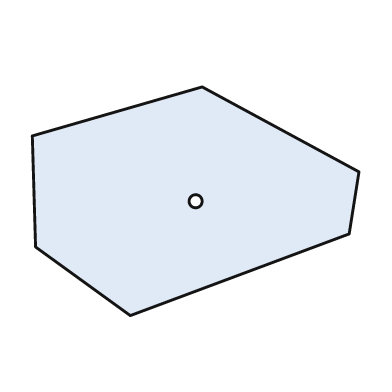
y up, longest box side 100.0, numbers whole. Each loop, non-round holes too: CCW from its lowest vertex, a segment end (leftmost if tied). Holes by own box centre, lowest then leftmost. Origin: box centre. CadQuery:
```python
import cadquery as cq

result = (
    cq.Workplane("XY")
    .moveTo(-20.0, -35.0)
    .lineTo(47.0, -10.0)
    .lineTo(50.0, 9.0)
    .lineTo(2.0, 35.0)
    .lineTo(-50.0, 20.0)
    .lineTo(-49.0, -14.0)
    .close()
    .moveTo(0.0, 0.0)
    .circle(2.0)
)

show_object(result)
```